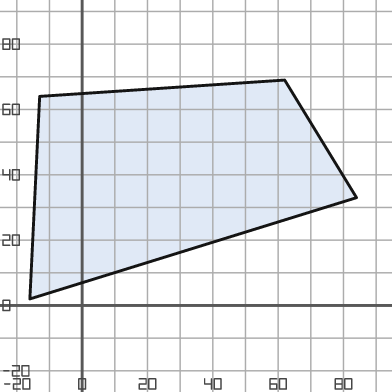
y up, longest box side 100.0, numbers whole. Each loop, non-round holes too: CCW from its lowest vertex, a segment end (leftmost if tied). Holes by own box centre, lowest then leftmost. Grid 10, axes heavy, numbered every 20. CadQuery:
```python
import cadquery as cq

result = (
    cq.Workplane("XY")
    .moveTo(-16.0, 2.0)
    .lineTo(84.0, 33.0)
    .lineTo(62.0, 69.0)
    .lineTo(-13.0, 64.0)
    .close()
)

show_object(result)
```